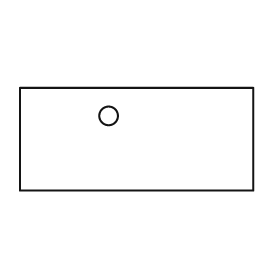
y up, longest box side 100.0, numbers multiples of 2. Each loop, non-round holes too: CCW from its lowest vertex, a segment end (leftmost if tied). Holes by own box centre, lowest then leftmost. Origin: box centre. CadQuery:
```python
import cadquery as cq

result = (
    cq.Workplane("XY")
    .moveTo(-50.0, -22.0)
    .lineTo(50.0, -22.0)
    .lineTo(50.0, 22.0)
    .lineTo(-50.0, 22.0)
    .close()
    .moveTo(-12.0, 10.0)
    .circle(4.0)
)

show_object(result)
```